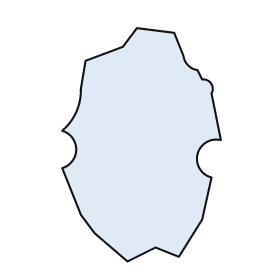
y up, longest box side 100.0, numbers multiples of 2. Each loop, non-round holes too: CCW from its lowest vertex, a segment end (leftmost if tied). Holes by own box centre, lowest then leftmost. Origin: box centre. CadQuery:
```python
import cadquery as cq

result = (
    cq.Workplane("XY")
    .moveTo(-6.0, -50.0)
    .lineTo(6.0, -44.0)
    .lineTo(16.0, -48.0)
    .lineTo(26.0, -32.0)
    .lineTo(30.0, -14.0)
    .threePointArc((24.0, -4.0), (34.0, 2.0))
    .lineTo(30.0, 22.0)
    .threePointArc((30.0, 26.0), (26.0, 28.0))
    .lineTo(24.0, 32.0)
    .threePointArc((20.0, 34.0), (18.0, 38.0))
    .lineTo(14.0, 48.0)
    .lineTo(-2.0, 50.0)
    .lineTo(-8.0, 42.0)
    .lineTo(-24.0, 36.0)
    .lineTo(-26.0, 24.0)
    .threePointArc((-28.0, 14.0), (-34.0, 6.0))
    .threePointArc((-28.0, -2.0), (-34.0, -10.0))
    .lineTo(-26.0, -30.0)
    .lineTo(-20.0, -38.0)
    .close()
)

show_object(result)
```